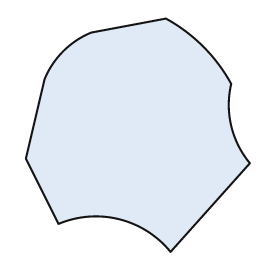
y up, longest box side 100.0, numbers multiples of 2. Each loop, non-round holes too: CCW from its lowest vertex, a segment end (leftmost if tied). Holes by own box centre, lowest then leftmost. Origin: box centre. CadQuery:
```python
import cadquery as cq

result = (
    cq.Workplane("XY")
    .moveTo(14.0, -50.0)
    .lineTo(48.0, -12.0)
    .threePointArc((40.0, 4.0), (40.0, 22.0))
    .threePointArc((28.0, 38.0), (12.0, 50.0))
    .lineTo(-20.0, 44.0)
    .threePointArc((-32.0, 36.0), (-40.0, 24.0))
    .lineTo(-48.0, -10.0)
    .lineTo(-34.0, -38.0)
    .threePointArc((-8.0, -36.0), (14.0, -50.0))
    .close()
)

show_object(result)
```